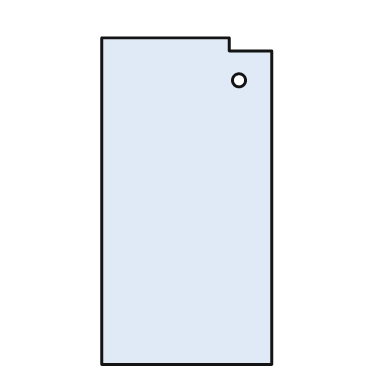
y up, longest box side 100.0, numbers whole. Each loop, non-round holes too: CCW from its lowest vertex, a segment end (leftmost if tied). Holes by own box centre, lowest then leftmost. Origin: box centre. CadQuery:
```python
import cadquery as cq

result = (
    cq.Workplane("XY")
    .moveTo(-26.0, -50.0)
    .lineTo(26.0, -50.0)
    .lineTo(26.0, 46.0)
    .lineTo(13.0, 46.0)
    .lineTo(13.0, 50.0)
    .lineTo(-26.0, 50.0)
    .close()
    .moveTo(16.0, 37.0)
    .circle(2.0)
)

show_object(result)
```